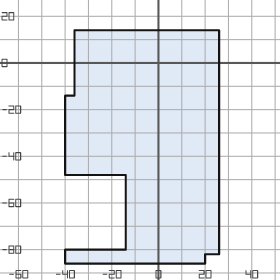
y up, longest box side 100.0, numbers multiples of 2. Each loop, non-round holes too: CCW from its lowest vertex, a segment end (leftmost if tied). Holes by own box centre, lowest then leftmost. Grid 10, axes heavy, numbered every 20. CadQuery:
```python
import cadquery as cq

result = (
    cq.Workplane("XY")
    .moveTo(-40.0, -86.0)
    .lineTo(20.0, -86.0)
    .lineTo(20.0, -82.0)
    .lineTo(26.0, -82.0)
    .lineTo(26.0, 14.0)
    .lineTo(-36.0, 14.0)
    .lineTo(-36.0, -14.0)
    .lineTo(-40.0, -14.0)
    .lineTo(-40.0, -48.0)
    .lineTo(-14.0, -48.0)
    .lineTo(-14.0, -80.0)
    .lineTo(-40.0, -80.0)
    .close()
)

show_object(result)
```